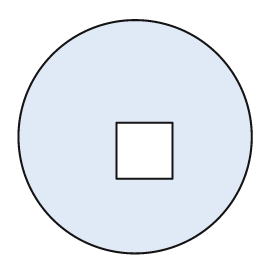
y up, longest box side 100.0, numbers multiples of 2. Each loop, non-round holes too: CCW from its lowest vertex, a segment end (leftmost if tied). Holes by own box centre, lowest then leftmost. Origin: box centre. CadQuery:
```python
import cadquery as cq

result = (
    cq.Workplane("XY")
    .moveTo(0.0, 0.0)
    .circle(50.0)
    .moveTo(-8.0, -18.0)
    .lineTo(16.0, -18.0)
    .lineTo(16.0, 6.0)
    .lineTo(-8.0, 6.0)
    .close()
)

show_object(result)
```